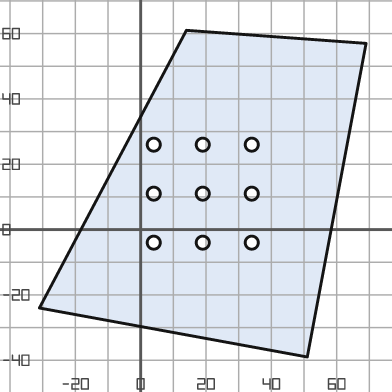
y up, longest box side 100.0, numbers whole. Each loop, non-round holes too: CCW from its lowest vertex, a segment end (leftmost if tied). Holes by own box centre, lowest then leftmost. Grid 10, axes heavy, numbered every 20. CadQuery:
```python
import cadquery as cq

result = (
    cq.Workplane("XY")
    .moveTo(51.0, -39.0)
    .lineTo(69.0, 57.0)
    .lineTo(14.0, 61.0)
    .lineTo(-31.0, -24.0)
    .close()
    .moveTo(4.0, -4.0)
    .circle(2.0)
    .moveTo(19.0, -4.0)
    .circle(2.0)
    .moveTo(34.0, -4.0)
    .circle(2.0)
    .moveTo(4.0, 11.0)
    .circle(2.0)
    .moveTo(19.0, 11.0)
    .circle(2.0)
    .moveTo(34.0, 11.0)
    .circle(2.0)
    .moveTo(4.0, 26.0)
    .circle(2.0)
    .moveTo(19.0, 26.0)
    .circle(2.0)
    .moveTo(34.0, 26.0)
    .circle(2.0)
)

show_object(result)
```